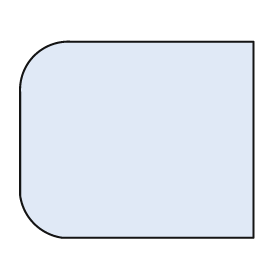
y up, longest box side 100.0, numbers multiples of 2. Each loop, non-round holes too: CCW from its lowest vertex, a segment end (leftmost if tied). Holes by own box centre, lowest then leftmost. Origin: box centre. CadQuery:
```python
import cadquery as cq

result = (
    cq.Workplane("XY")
    .moveTo(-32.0, -42.0)
    .lineTo(50.0, -42.0)
    .lineTo(50.0, 42.0)
    .lineTo(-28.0, 42.0)
    .threePointArc((-44.0, 36.0), (-50.0, 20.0))
    .lineTo(-50.0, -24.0)
    .threePointArc((-44.0, -36.0), (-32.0, -42.0))
    .close()
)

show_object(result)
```